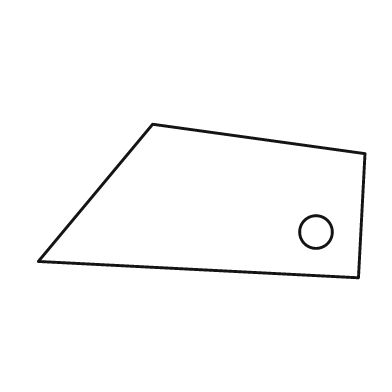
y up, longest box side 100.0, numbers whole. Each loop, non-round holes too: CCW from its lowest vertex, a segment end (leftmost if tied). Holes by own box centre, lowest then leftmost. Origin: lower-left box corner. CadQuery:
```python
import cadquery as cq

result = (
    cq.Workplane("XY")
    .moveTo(98.0, 0.0)
    .lineTo(100.0, 38.0)
    .lineTo(35.0, 47.0)
    .lineTo(0.0, 5.0)
    .close()
    .moveTo(85.0, 14.0)
    .circle(5.0)
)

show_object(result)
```